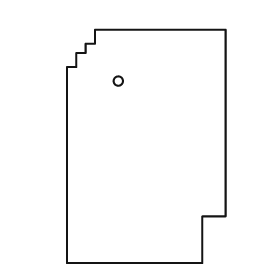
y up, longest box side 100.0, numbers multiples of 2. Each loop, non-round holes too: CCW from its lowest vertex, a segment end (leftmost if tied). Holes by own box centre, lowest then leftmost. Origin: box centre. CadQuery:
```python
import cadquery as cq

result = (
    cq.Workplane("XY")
    .moveTo(-34.0, -50.0)
    .lineTo(24.0, -50.0)
    .lineTo(24.0, -30.0)
    .lineTo(34.0, -30.0)
    .lineTo(34.0, 50.0)
    .lineTo(-22.0, 50.0)
    .lineTo(-22.0, 44.0)
    .lineTo(-26.0, 44.0)
    .lineTo(-26.0, 40.0)
    .lineTo(-30.0, 40.0)
    .lineTo(-30.0, 34.0)
    .lineTo(-34.0, 34.0)
    .close()
    .moveTo(-12.0, 28.0)
    .circle(2.0)
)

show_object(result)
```